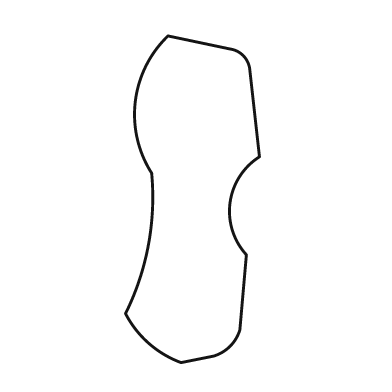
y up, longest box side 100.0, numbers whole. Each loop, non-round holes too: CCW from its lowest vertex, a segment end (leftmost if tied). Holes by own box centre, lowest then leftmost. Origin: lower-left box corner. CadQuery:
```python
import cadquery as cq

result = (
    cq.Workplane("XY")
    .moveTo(17.0, 0.0)
    .lineTo(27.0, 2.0)
    .threePointArc((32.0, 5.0), (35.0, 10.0))
    .lineTo(37.0, 33.0)
    .threePointArc((32.0, 49.0), (41.0, 63.0))
    .lineTo(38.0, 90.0)
    .threePointArc((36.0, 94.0), (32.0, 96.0))
    .lineTo(13.0, 100.0)
    .threePointArc((3.0, 80.0), (8.0, 58.0))
    .threePointArc((7.0, 36.0), (0.0, 15.0))
    .threePointArc((7.0, 6.0), (17.0, 0.0))
    .close()
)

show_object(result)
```